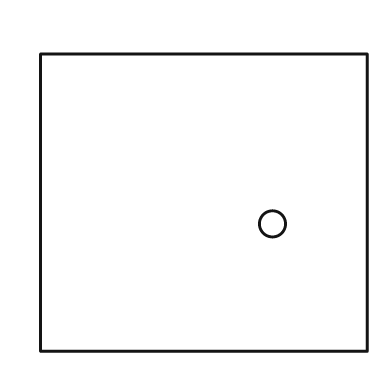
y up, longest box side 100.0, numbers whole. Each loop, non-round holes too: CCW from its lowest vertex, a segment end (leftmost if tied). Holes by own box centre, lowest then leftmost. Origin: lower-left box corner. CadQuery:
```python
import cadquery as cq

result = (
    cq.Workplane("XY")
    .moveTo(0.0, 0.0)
    .lineTo(100.0, 0.0)
    .lineTo(100.0, 91.0)
    .lineTo(0.0, 91.0)
    .close()
    .moveTo(71.0, 39.0)
    .circle(4.0)
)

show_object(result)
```